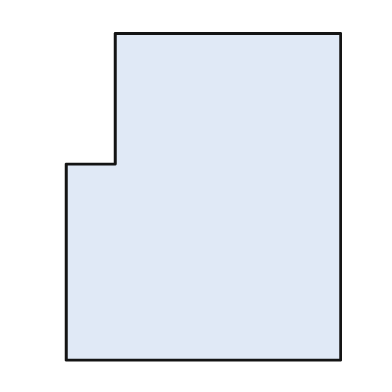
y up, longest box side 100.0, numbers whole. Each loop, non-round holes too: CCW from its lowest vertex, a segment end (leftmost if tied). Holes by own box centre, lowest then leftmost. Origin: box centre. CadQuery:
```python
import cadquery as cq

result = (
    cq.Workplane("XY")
    .moveTo(-42.0, -50.0)
    .lineTo(42.0, -50.0)
    .lineTo(42.0, 50.0)
    .lineTo(-27.0, 50.0)
    .lineTo(-27.0, 10.0)
    .lineTo(-42.0, 10.0)
    .close()
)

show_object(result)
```